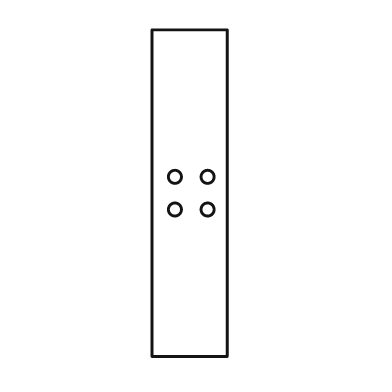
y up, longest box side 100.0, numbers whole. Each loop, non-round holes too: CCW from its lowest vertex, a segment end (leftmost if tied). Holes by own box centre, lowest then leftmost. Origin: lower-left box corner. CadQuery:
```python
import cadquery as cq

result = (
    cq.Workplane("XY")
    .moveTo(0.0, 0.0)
    .lineTo(23.0, 0.0)
    .lineTo(23.0, 100.0)
    .lineTo(0.0, 100.0)
    .close()
    .moveTo(7.0, 45.0)
    .circle(2.0)
    .moveTo(17.0, 45.0)
    .circle(2.0)
    .moveTo(7.0, 55.0)
    .circle(2.0)
    .moveTo(17.0, 55.0)
    .circle(2.0)
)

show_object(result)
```